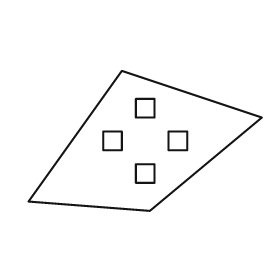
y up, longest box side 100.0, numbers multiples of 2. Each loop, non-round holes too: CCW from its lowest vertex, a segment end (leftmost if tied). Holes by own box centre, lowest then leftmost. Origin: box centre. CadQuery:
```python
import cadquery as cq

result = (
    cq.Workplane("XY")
    .moveTo(2.0, -30.0)
    .lineTo(50.0, 10.0)
    .lineTo(-10.0, 30.0)
    .lineTo(-50.0, -26.0)
    .close()
    .moveTo(-4.0, -18.0)
    .lineTo(4.0, -18.0)
    .lineTo(4.0, -10.0)
    .lineTo(-4.0, -10.0)
    .close()
    .moveTo(-18.0, -4.0)
    .lineTo(-10.0, -4.0)
    .lineTo(-10.0, 4.0)
    .lineTo(-18.0, 4.0)
    .close()
    .moveTo(10.0, -4.0)
    .lineTo(18.0, -4.0)
    .lineTo(18.0, 4.0)
    .lineTo(10.0, 4.0)
    .close()
    .moveTo(-4.0, 10.0)
    .lineTo(4.0, 10.0)
    .lineTo(4.0, 18.0)
    .lineTo(-4.0, 18.0)
    .close()
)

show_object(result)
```